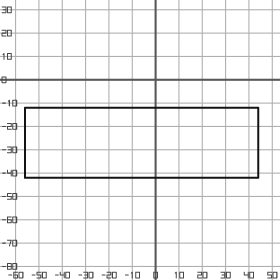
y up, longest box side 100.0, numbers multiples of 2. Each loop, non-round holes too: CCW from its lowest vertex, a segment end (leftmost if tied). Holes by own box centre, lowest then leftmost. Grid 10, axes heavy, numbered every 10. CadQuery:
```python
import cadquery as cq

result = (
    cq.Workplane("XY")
    .moveTo(-56.0, -42.0)
    .lineTo(44.0, -42.0)
    .lineTo(44.0, -12.0)
    .lineTo(-56.0, -12.0)
    .close()
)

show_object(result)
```